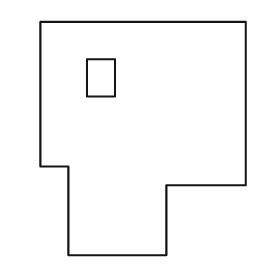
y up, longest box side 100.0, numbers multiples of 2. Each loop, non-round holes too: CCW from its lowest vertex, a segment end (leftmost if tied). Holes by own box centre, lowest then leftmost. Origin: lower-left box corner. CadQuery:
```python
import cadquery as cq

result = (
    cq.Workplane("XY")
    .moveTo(12.0, 0.0)
    .lineTo(54.0, 0.0)
    .lineTo(54.0, 30.0)
    .lineTo(88.0, 30.0)
    .lineTo(88.0, 100.0)
    .lineTo(0.0, 100.0)
    .lineTo(0.0, 38.0)
    .lineTo(12.0, 38.0)
    .close()
    .moveTo(20.0, 68.0)
    .lineTo(32.0, 68.0)
    .lineTo(32.0, 84.0)
    .lineTo(20.0, 84.0)
    .close()
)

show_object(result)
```